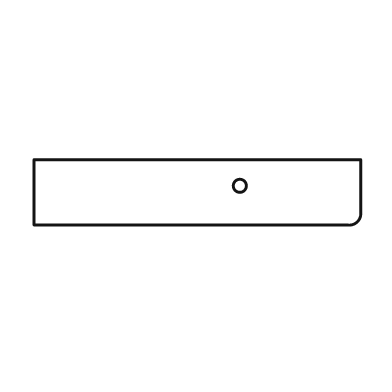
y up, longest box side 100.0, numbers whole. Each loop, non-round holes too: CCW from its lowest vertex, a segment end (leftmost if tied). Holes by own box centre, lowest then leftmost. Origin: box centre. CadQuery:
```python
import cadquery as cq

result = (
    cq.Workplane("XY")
    .moveTo(-50.0, -10.0)
    .lineTo(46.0, -10.0)
    .threePointArc((49.0, -9.0), (50.0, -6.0))
    .lineTo(50.0, 10.0)
    .lineTo(-50.0, 10.0)
    .close()
    .moveTo(13.0, 2.0)
    .circle(2.0)
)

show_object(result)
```